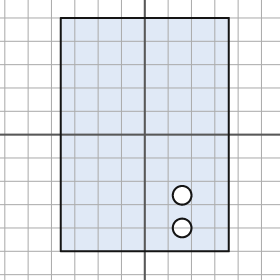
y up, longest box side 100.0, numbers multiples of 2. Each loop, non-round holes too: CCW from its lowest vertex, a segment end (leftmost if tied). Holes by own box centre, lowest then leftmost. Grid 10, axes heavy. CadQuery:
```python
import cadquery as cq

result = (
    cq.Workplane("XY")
    .moveTo(-36.0, -50.0)
    .lineTo(36.0, -50.0)
    .lineTo(36.0, 50.0)
    .lineTo(-36.0, 50.0)
    .close()
    .moveTo(16.0, -40.0)
    .circle(4.0)
    .moveTo(16.0, -26.0)
    .circle(4.0)
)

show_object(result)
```